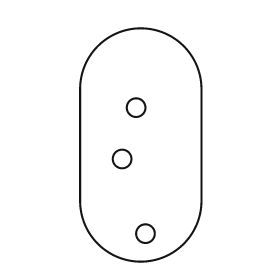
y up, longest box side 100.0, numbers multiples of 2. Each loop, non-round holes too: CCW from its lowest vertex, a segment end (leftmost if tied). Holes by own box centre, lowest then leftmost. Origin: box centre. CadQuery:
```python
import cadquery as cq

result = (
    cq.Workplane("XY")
    .moveTo(-26.0, -24.0)
    .threePointArc((0.0, -50.0), (26.0, -24.0))
    .lineTo(26.0, 24.0)
    .threePointArc((0.0, 50.0), (-26.0, 24.0))
    .close()
    .moveTo(2.0, -38.0)
    .circle(4.0)
    .moveTo(-8.0, -6.0)
    .circle(4.0)
    .moveTo(-2.0, 16.0)
    .circle(4.0)
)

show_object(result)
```